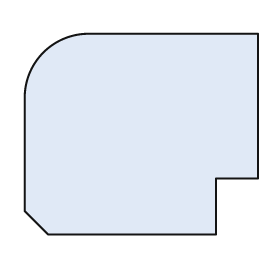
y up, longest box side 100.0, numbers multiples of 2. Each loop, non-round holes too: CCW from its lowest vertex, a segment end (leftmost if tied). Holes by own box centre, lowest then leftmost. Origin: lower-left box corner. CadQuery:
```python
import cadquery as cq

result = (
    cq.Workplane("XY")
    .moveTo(10.0, 0.0)
    .lineTo(82.0, 0.0)
    .lineTo(82.0, 24.0)
    .lineTo(100.0, 24.0)
    .lineTo(100.0, 86.0)
    .lineTo(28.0, 86.0)
    .threePointArc((8.0, 78.0), (0.0, 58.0))
    .lineTo(0.0, 10.0)
    .close()
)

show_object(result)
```